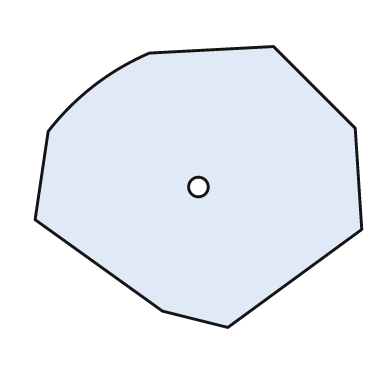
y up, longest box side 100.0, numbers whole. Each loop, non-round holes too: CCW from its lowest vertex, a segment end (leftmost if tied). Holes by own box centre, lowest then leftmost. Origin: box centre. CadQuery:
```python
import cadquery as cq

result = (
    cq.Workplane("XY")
    .moveTo(9.0, -43.0)
    .lineTo(50.0, -13.0)
    .lineTo(48.0, 18.0)
    .lineTo(23.0, 43.0)
    .lineTo(-15.0, 41.0)
    .threePointArc((-32.0, 31.0), (-46.0, 17.0))
    .lineTo(-50.0, -10.0)
    .lineTo(-11.0, -38.0)
    .close()
    .moveTo(0.0, 0.0)
    .circle(3.0)
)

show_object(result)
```